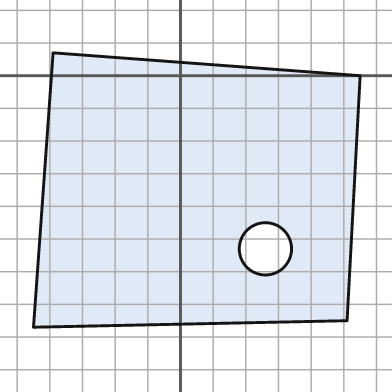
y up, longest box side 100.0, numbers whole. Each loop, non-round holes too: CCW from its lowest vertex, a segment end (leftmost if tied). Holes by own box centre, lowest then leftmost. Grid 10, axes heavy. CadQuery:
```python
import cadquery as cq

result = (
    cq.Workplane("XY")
    .moveTo(-45.0, -77.0)
    .lineTo(51.0, -75.0)
    .lineTo(55.0, 0.0)
    .lineTo(-39.0, 7.0)
    .close()
    .moveTo(26.0, -53.0)
    .circle(8.0)
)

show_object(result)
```